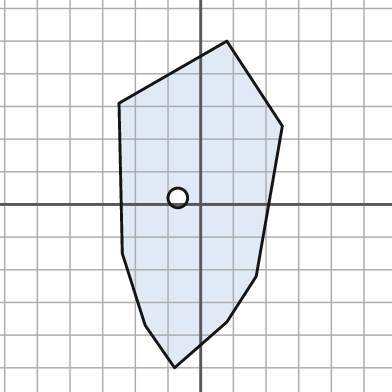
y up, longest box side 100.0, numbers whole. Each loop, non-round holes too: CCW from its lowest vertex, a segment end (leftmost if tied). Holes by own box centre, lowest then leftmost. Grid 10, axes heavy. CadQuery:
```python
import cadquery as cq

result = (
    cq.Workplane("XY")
    .moveTo(-8.0, -50.0)
    .lineTo(8.0, -36.0)
    .lineTo(17.0, -22.0)
    .lineTo(25.0, 24.0)
    .lineTo(8.0, 50.0)
    .lineTo(-25.0, 31.0)
    .lineTo(-24.0, -15.0)
    .lineTo(-17.0, -37.0)
    .close()
    .moveTo(-7.0, 2.0)
    .circle(3.0)
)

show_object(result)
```